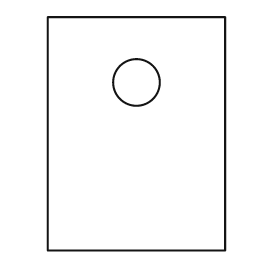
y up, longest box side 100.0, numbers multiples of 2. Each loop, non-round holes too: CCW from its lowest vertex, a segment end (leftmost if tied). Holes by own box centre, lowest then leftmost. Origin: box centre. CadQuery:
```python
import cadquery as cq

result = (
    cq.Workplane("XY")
    .moveTo(-38.0, -50.0)
    .lineTo(38.0, -50.0)
    .lineTo(38.0, 50.0)
    .lineTo(-38.0, 50.0)
    .close()
    .moveTo(0.0, 22.0)
    .circle(10.0)
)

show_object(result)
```